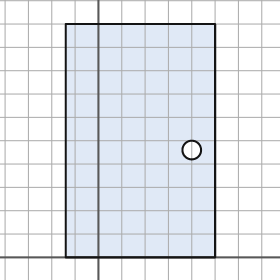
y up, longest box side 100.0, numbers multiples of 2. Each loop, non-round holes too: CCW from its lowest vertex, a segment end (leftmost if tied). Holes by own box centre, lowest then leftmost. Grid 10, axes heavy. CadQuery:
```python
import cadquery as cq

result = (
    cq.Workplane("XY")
    .moveTo(-14.0, 0.0)
    .lineTo(50.0, 0.0)
    .lineTo(50.0, 100.0)
    .lineTo(-14.0, 100.0)
    .close()
    .moveTo(40.0, 46.0)
    .circle(4.0)
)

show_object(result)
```